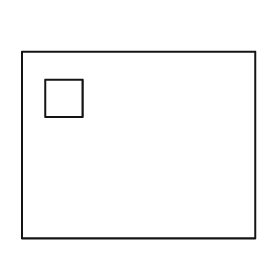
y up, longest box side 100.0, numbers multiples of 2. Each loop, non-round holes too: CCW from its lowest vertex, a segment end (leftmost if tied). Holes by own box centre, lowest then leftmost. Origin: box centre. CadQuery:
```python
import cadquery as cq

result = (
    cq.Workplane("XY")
    .moveTo(-50.0, -40.0)
    .lineTo(50.0, -40.0)
    .lineTo(50.0, 40.0)
    .lineTo(-50.0, 40.0)
    .close()
    .moveTo(-40.0, 12.0)
    .lineTo(-24.0, 12.0)
    .lineTo(-24.0, 28.0)
    .lineTo(-40.0, 28.0)
    .close()
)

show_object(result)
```